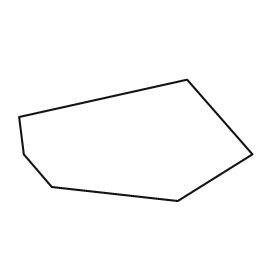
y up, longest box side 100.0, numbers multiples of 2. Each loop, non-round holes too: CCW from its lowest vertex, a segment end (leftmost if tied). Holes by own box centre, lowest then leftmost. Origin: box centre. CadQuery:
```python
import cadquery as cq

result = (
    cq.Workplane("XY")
    .moveTo(18.0, -26.0)
    .lineTo(50.0, -6.0)
    .lineTo(22.0, 26.0)
    .lineTo(-50.0, 10.0)
    .lineTo(-48.0, -6.0)
    .lineTo(-36.0, -20.0)
    .close()
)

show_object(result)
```